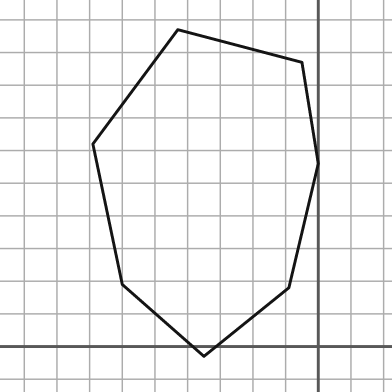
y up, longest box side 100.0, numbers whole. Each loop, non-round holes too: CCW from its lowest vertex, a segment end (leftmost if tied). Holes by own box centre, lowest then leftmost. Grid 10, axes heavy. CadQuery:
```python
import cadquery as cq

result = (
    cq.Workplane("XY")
    .moveTo(-35.0, -3.0)
    .lineTo(-9.0, 18.0)
    .lineTo(0.0, 56.0)
    .lineTo(-5.0, 87.0)
    .lineTo(-43.0, 97.0)
    .lineTo(-69.0, 62.0)
    .lineTo(-60.0, 19.0)
    .close()
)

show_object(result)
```